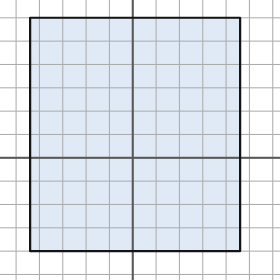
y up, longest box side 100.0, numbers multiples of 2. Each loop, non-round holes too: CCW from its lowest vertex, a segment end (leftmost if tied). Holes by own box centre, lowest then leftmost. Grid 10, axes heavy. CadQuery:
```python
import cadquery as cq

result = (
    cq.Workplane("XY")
    .moveTo(-44.0, -40.0)
    .lineTo(46.0, -40.0)
    .lineTo(46.0, 60.0)
    .lineTo(-44.0, 60.0)
    .close()
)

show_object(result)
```